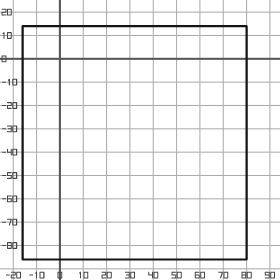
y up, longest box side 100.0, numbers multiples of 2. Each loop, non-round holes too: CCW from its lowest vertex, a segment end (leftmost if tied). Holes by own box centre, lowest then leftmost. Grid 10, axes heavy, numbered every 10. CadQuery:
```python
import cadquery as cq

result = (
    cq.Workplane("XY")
    .moveTo(-16.0, -86.0)
    .lineTo(80.0, -86.0)
    .lineTo(80.0, 14.0)
    .lineTo(-16.0, 14.0)
    .close()
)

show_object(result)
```